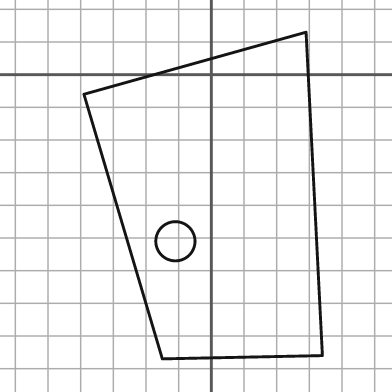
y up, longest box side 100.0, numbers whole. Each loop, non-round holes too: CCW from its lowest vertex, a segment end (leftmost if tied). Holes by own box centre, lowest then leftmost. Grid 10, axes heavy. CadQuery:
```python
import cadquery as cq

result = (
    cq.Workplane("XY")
    .moveTo(-15.0, -87.0)
    .lineTo(34.0, -86.0)
    .lineTo(29.0, 13.0)
    .lineTo(-39.0, -6.0)
    .close()
    .moveTo(-11.0, -51.0)
    .circle(6.0)
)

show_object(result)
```